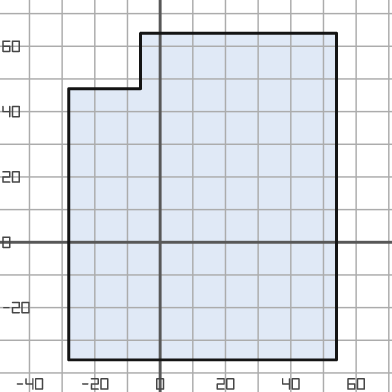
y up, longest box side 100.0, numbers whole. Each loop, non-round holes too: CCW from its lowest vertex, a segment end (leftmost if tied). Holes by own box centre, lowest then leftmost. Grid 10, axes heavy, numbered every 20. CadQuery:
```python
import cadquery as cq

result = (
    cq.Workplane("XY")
    .moveTo(-28.0, -36.0)
    .lineTo(54.0, -36.0)
    .lineTo(54.0, 64.0)
    .lineTo(-6.0, 64.0)
    .lineTo(-6.0, 47.0)
    .lineTo(-28.0, 47.0)
    .close()
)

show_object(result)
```